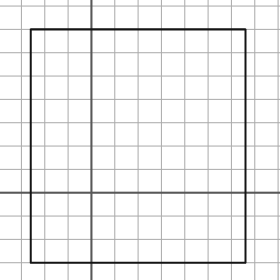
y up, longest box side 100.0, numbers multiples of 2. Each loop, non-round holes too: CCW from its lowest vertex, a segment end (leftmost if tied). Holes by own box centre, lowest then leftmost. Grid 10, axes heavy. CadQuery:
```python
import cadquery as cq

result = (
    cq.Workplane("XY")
    .moveTo(-26.0, -30.0)
    .lineTo(66.0, -30.0)
    .lineTo(66.0, 70.0)
    .lineTo(-26.0, 70.0)
    .close()
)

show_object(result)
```